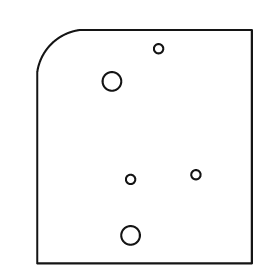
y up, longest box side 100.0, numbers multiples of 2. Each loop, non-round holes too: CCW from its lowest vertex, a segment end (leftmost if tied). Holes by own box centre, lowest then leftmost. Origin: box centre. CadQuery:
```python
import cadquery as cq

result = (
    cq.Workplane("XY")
    .moveTo(-46.0, -50.0)
    .lineTo(46.0, -50.0)
    .lineTo(46.0, 50.0)
    .lineTo(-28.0, 50.0)
    .threePointArc((-40.0, 44.0), (-46.0, 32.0))
    .close()
    .moveTo(-6.0, -38.0)
    .circle(4.0)
    .moveTo(-6.0, -14.0)
    .circle(2.0)
    .moveTo(22.0, -12.0)
    .circle(2.0)
    .moveTo(-14.0, 28.0)
    .circle(4.0)
    .moveTo(6.0, 42.0)
    .circle(2.0)
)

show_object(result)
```